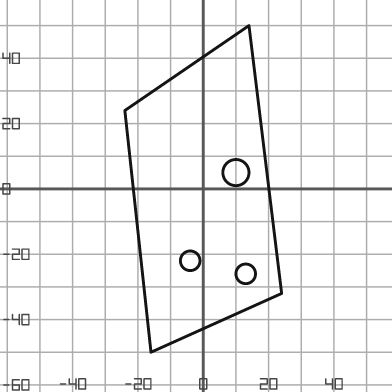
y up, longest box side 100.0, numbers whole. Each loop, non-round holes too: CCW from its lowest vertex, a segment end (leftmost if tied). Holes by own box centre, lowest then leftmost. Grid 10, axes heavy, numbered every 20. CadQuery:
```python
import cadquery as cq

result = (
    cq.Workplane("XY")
    .moveTo(-16.0, -50.0)
    .lineTo(24.0, -32.0)
    .lineTo(14.0, 50.0)
    .lineTo(-24.0, 24.0)
    .close()
    .moveTo(13.0, -26.0)
    .circle(3.0)
    .moveTo(-4.0, -22.0)
    .circle(3.0)
    .moveTo(10.0, 5.0)
    .circle(4.0)
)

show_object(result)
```